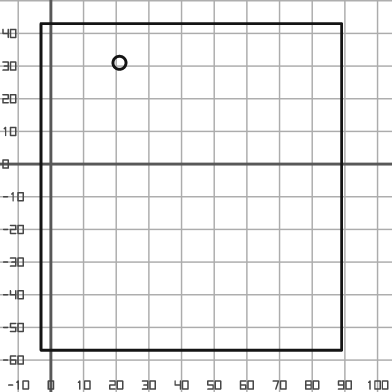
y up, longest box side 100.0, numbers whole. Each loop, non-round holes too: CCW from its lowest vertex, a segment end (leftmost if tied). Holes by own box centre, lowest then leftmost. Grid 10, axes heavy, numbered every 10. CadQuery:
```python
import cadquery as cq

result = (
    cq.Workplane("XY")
    .moveTo(-3.0, -57.0)
    .lineTo(89.0, -57.0)
    .lineTo(89.0, 43.0)
    .lineTo(-3.0, 43.0)
    .close()
    .moveTo(21.0, 31.0)
    .circle(2.0)
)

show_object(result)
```